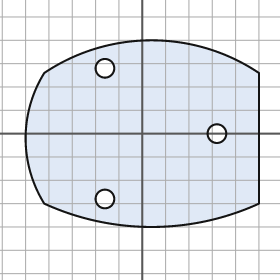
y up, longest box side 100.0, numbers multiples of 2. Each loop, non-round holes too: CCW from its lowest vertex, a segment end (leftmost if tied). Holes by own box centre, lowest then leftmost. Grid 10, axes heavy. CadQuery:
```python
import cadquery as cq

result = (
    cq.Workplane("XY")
    .moveTo(-42.0, -30.0)
    .threePointArc((4.0, -40.0), (50.0, -30.0))
    .lineTo(50.0, 26.0)
    .threePointArc((4.0, 40.0), (-42.0, 26.0))
    .threePointArc((-50.0, -2.0), (-42.0, -30.0))
    .close()
    .moveTo(-16.0, -28.0)
    .circle(4.0)
    .moveTo(32.0, 0.0)
    .circle(4.0)
    .moveTo(-16.0, 28.0)
    .circle(4.0)
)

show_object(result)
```